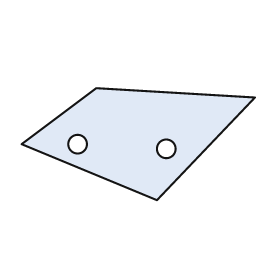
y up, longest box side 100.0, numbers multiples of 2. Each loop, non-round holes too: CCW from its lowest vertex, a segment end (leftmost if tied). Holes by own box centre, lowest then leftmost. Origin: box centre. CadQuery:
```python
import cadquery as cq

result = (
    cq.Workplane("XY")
    .moveTo(8.0, -24.0)
    .lineTo(50.0, 20.0)
    .lineTo(-18.0, 24.0)
    .lineTo(-50.0, 0.0)
    .close()
    .moveTo(12.0, -2.0)
    .circle(4.0)
    .moveTo(-26.0, 0.0)
    .circle(4.0)
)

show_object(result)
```